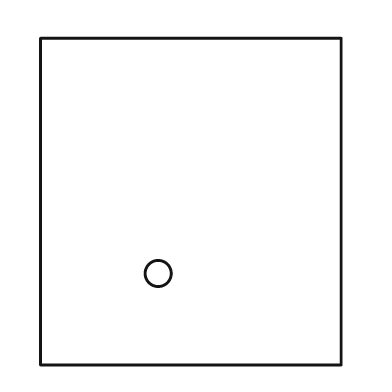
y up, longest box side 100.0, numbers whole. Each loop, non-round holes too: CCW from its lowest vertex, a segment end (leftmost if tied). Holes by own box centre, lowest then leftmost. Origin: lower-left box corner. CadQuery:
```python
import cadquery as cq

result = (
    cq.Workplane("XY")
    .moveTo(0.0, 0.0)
    .lineTo(92.0, 0.0)
    .lineTo(92.0, 100.0)
    .lineTo(0.0, 100.0)
    .close()
    .moveTo(36.0, 28.0)
    .circle(4.0)
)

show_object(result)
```